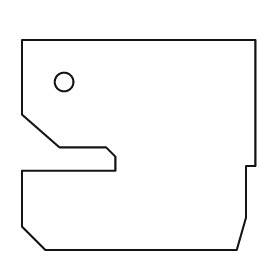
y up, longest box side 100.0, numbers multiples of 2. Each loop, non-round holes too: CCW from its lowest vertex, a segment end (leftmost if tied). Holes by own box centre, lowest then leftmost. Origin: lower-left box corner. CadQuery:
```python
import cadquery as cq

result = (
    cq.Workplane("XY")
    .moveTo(10.0, 0.0)
    .lineTo(92.0, 0.0)
    .lineTo(96.0, 14.0)
    .lineTo(96.0, 36.0)
    .lineTo(100.0, 36.0)
    .lineTo(100.0, 90.0)
    .lineTo(0.0, 90.0)
    .lineTo(0.0, 58.0)
    .lineTo(16.0, 44.0)
    .lineTo(36.0, 44.0)
    .lineTo(40.0, 40.0)
    .lineTo(40.0, 34.0)
    .lineTo(0.0, 34.0)
    .lineTo(0.0, 10.0)
    .close()
    .moveTo(18.0, 72.0)
    .circle(4.0)
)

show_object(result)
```